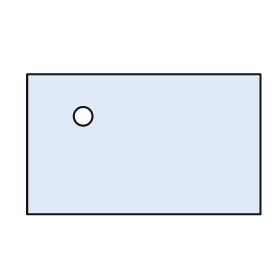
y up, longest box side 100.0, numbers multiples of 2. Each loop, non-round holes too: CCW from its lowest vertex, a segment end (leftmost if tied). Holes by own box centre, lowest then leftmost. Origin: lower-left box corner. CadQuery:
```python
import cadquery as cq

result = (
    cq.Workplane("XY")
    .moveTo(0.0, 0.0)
    .lineTo(100.0, 0.0)
    .lineTo(100.0, 60.0)
    .lineTo(0.0, 60.0)
    .close()
    .moveTo(24.0, 42.0)
    .circle(4.0)
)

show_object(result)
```